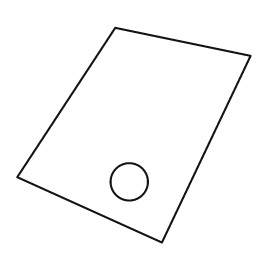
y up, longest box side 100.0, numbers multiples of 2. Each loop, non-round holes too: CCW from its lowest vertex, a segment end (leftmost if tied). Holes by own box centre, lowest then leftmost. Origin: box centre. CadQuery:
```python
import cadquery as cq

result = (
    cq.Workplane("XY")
    .moveTo(12.0, -46.0)
    .lineTo(50.0, 34.0)
    .lineTo(-8.0, 46.0)
    .lineTo(-50.0, -18.0)
    .close()
    .moveTo(-2.0, -20.0)
    .circle(8.0)
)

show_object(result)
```